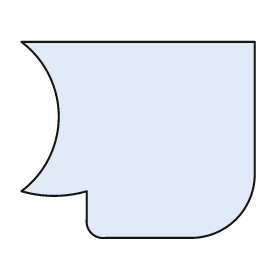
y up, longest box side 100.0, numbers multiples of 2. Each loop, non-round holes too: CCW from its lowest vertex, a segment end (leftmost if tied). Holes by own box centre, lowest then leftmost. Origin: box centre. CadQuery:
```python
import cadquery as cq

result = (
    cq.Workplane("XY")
    .moveTo(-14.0, -42.0)
    .lineTo(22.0, -42.0)
    .threePointArc((42.0, -34.0), (50.0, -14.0))
    .lineTo(50.0, 42.0)
    .lineTo(-50.0, 42.0)
    .threePointArc((-34.0, 10.0), (-50.0, -22.0))
    .threePointArc((-36.0, -24.0), (-22.0, -22.0))
    .lineTo(-22.0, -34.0)
    .threePointArc((-20.0, -40.0), (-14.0, -42.0))
    .close()
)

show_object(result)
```